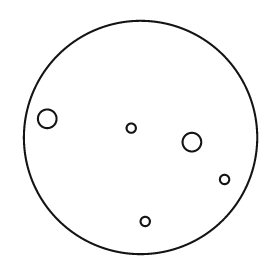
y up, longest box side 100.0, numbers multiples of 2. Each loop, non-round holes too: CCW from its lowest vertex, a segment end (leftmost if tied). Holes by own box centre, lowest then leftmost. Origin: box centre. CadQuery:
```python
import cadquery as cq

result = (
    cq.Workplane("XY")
    .moveTo(0.0, 0.0)
    .circle(50.0)
    .moveTo(2.0, -36.0)
    .circle(2.0)
    .moveTo(36.0, -18.0)
    .circle(2.0)
    .moveTo(22.0, -2.0)
    .circle(4.0)
    .moveTo(-4.0, 4.0)
    .circle(2.0)
    .moveTo(-40.0, 8.0)
    .circle(4.0)
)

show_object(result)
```